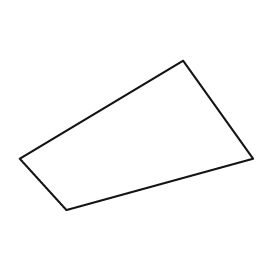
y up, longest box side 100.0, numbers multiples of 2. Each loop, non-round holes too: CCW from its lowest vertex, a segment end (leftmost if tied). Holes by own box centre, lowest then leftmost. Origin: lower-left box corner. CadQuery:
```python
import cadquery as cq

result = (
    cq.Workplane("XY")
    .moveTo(20.0, 0.0)
    .lineTo(100.0, 22.0)
    .lineTo(70.0, 64.0)
    .lineTo(0.0, 22.0)
    .close()
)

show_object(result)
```